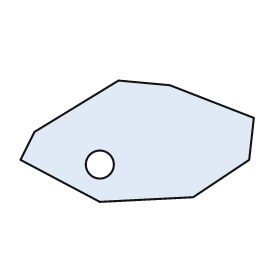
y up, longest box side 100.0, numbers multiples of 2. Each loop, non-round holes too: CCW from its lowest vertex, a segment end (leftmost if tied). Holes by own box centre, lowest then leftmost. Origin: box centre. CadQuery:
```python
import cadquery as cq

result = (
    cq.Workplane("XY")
    .moveTo(-16.0, -26.0)
    .lineTo(24.0, -24.0)
    .lineTo(48.0, -8.0)
    .lineTo(50.0, 10.0)
    .lineTo(14.0, 24.0)
    .lineTo(-8.0, 26.0)
    .lineTo(-44.0, 4.0)
    .lineTo(-50.0, -8.0)
    .close()
    .moveTo(-16.0, -10.0)
    .circle(6.0)
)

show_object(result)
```